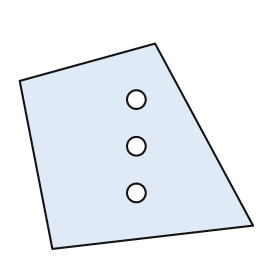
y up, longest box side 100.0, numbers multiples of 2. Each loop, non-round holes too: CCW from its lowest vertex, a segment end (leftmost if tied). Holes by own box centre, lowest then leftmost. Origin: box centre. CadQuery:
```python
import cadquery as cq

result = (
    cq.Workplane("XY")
    .moveTo(-36.0, -44.0)
    .lineTo(50.0, -34.0)
    .lineTo(8.0, 44.0)
    .lineTo(-50.0, 28.0)
    .close()
    .moveTo(0.0, -20.0)
    .circle(4.0)
    .moveTo(0.0, 0.0)
    .circle(4.0)
    .moveTo(0.0, 20.0)
    .circle(4.0)
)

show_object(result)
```